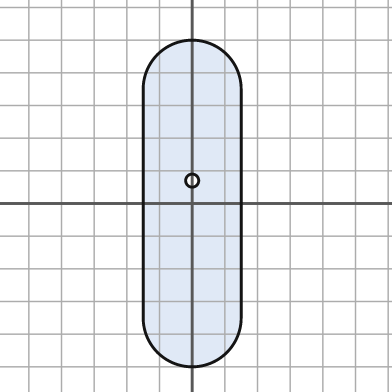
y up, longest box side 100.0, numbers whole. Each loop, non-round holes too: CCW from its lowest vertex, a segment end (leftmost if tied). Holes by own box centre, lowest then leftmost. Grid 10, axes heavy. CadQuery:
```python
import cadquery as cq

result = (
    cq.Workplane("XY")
    .moveTo(-15.0, -35.0)
    .threePointArc((0.0, -50.0), (15.0, -35.0))
    .lineTo(15.0, 35.0)
    .threePointArc((0.0, 50.0), (-15.0, 35.0))
    .close()
    .moveTo(0.0, 7.0)
    .circle(2.0)
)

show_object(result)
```